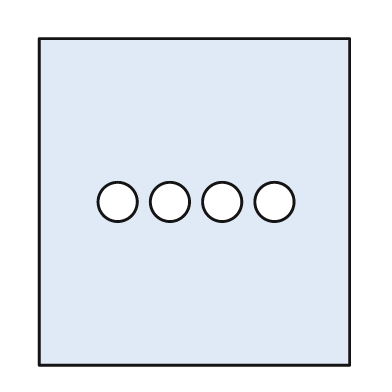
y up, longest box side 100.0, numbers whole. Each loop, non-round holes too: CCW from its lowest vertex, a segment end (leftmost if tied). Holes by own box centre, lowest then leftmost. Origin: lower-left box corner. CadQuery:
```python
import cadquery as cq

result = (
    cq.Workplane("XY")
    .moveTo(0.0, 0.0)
    .lineTo(95.0, 0.0)
    .lineTo(95.0, 100.0)
    .lineTo(0.0, 100.0)
    .close()
    .moveTo(24.0, 50.0)
    .circle(6.0)
    .moveTo(40.0, 50.0)
    .circle(6.0)
    .moveTo(56.0, 50.0)
    .circle(6.0)
    .moveTo(72.0, 50.0)
    .circle(6.0)
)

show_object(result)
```